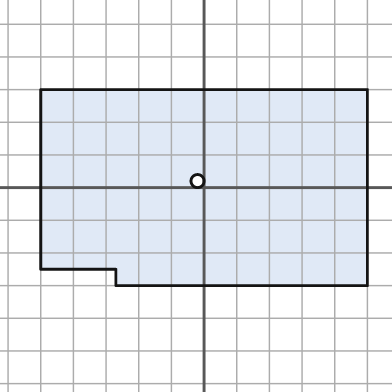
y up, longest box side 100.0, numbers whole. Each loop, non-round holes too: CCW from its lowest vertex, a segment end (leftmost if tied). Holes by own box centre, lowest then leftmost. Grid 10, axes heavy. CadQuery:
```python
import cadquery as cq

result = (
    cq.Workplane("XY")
    .moveTo(-27.0, -30.0)
    .lineTo(50.0, -30.0)
    .lineTo(50.0, 30.0)
    .lineTo(-50.0, 30.0)
    .lineTo(-50.0, -25.0)
    .lineTo(-27.0, -25.0)
    .close()
    .moveTo(-2.0, 2.0)
    .circle(2.0)
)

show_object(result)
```